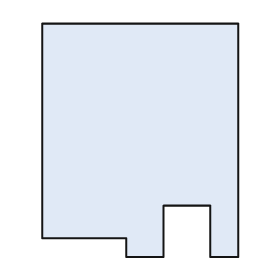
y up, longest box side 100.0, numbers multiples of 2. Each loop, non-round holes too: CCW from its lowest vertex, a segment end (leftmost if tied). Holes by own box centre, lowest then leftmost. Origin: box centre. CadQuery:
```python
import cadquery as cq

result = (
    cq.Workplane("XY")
    .moveTo(-6.0, -50.0)
    .lineTo(10.0, -50.0)
    .lineTo(10.0, -28.0)
    .lineTo(30.0, -28.0)
    .lineTo(30.0, -50.0)
    .lineTo(42.0, -50.0)
    .lineTo(42.0, 50.0)
    .lineTo(-42.0, 50.0)
    .lineTo(-42.0, -42.0)
    .lineTo(-6.0, -42.0)
    .close()
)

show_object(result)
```